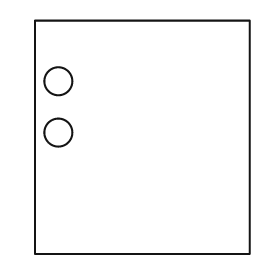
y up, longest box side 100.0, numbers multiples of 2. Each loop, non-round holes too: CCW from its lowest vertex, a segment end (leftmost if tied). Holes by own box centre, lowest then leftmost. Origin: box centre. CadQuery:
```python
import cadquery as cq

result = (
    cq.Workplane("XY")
    .moveTo(-46.0, -50.0)
    .lineTo(46.0, -50.0)
    .lineTo(46.0, 50.0)
    .lineTo(-46.0, 50.0)
    .close()
    .moveTo(-36.0, 2.0)
    .circle(6.0)
    .moveTo(-36.0, 24.0)
    .circle(6.0)
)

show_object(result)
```